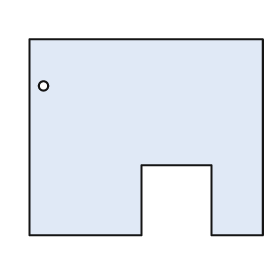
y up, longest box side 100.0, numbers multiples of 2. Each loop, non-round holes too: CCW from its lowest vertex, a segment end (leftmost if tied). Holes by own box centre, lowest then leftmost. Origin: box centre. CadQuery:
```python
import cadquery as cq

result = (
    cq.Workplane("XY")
    .moveTo(-50.0, -42.0)
    .lineTo(-2.0, -42.0)
    .lineTo(-2.0, -12.0)
    .lineTo(28.0, -12.0)
    .lineTo(28.0, -42.0)
    .lineTo(50.0, -42.0)
    .lineTo(50.0, 42.0)
    .lineTo(-50.0, 42.0)
    .close()
    .moveTo(-44.0, 22.0)
    .circle(2.0)
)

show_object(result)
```